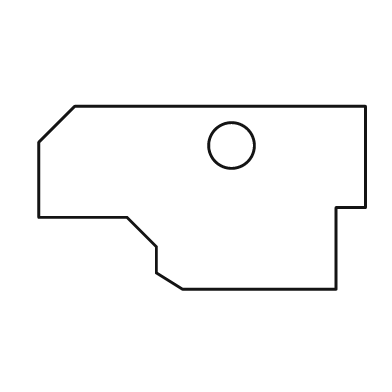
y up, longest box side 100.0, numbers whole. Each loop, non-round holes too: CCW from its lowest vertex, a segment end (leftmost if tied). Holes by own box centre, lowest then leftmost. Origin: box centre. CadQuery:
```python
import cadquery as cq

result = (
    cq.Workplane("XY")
    .moveTo(-6.0, -28.0)
    .lineTo(41.0, -28.0)
    .lineTo(41.0, -3.0)
    .lineTo(50.0, -3.0)
    .lineTo(50.0, 28.0)
    .lineTo(-39.0, 28.0)
    .lineTo(-50.0, 17.0)
    .lineTo(-50.0, -6.0)
    .lineTo(-23.0, -6.0)
    .lineTo(-14.0, -15.0)
    .lineTo(-14.0, -23.0)
    .close()
    .moveTo(9.0, 16.0)
    .circle(7.0)
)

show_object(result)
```